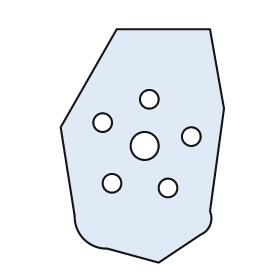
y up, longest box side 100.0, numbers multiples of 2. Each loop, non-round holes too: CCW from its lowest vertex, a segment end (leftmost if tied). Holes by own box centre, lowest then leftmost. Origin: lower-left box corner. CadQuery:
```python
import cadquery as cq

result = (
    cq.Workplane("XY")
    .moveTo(42.0, 0.0)
    .lineTo(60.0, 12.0)
    .threePointArc((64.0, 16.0), (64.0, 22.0))
    .lineTo(70.0, 66.0)
    .lineTo(64.0, 100.0)
    .lineTo(24.0, 100.0)
    .lineTo(0.0, 58.0)
    .lineTo(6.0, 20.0)
    .threePointArc((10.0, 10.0), (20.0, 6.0))
    .close()
    .moveTo(46.0, 32.0)
    .circle(4.0)
    .moveTo(22.0, 34.0)
    .circle(4.0)
    .moveTo(36.0, 50.0)
    .circle(6.0)
    .moveTo(56.0, 54.0)
    .circle(4.0)
    .moveTo(18.0, 60.0)
    .circle(4.0)
    .moveTo(38.0, 70.0)
    .circle(4.0)
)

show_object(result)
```